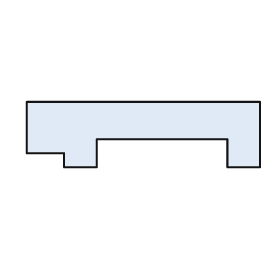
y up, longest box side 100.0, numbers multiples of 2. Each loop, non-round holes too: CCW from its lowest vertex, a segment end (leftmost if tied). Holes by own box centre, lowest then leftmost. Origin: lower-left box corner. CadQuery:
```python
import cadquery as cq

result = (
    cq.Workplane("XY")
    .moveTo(16.0, 0.0)
    .lineTo(30.0, 0.0)
    .lineTo(30.0, 12.0)
    .lineTo(86.0, 12.0)
    .lineTo(86.0, 0.0)
    .lineTo(100.0, 0.0)
    .lineTo(100.0, 28.0)
    .lineTo(0.0, 28.0)
    .lineTo(0.0, 6.0)
    .lineTo(16.0, 6.0)
    .close()
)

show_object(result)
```